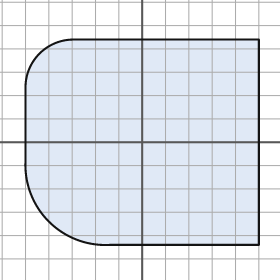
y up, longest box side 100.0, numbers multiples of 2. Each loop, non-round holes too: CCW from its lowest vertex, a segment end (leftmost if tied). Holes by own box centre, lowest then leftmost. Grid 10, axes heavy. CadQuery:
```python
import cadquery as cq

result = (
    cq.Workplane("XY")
    .moveTo(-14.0, -44.0)
    .lineTo(50.0, -44.0)
    .lineTo(50.0, 44.0)
    .lineTo(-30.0, 44.0)
    .threePointArc((-44.0, 38.0), (-50.0, 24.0))
    .lineTo(-50.0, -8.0)
    .threePointArc((-40.0, -34.0), (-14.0, -44.0))
    .close()
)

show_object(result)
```